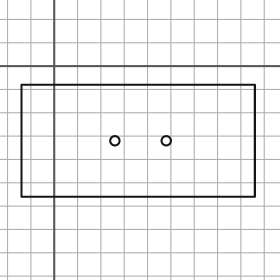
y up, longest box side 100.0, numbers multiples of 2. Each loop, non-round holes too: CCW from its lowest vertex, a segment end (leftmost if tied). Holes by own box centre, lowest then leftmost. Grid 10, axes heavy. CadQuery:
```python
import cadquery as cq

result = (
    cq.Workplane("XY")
    .moveTo(-14.0, -56.0)
    .lineTo(86.0, -56.0)
    .lineTo(86.0, -8.0)
    .lineTo(-14.0, -8.0)
    .close()
    .moveTo(26.0, -32.0)
    .circle(2.0)
    .moveTo(48.0, -32.0)
    .circle(2.0)
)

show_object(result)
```